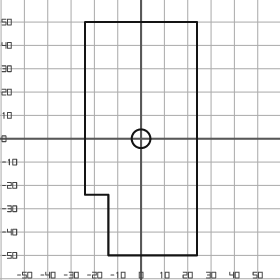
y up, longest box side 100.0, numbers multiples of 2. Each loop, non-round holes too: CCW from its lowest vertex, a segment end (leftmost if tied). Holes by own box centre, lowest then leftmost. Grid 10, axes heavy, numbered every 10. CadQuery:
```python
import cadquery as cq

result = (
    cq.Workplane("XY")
    .moveTo(-14.0, -50.0)
    .lineTo(24.0, -50.0)
    .lineTo(24.0, 50.0)
    .lineTo(-24.0, 50.0)
    .lineTo(-24.0, -24.0)
    .lineTo(-14.0, -24.0)
    .close()
    .moveTo(0.0, 0.0)
    .circle(4.0)
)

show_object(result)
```